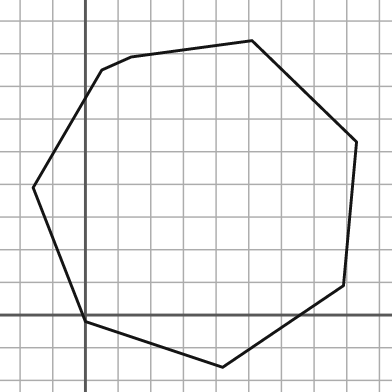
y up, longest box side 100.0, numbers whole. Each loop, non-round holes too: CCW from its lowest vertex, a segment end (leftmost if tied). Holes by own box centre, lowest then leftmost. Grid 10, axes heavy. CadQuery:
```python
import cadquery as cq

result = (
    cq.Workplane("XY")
    .moveTo(42.0, -16.0)
    .lineTo(79.0, 9.0)
    .lineTo(83.0, 53.0)
    .lineTo(51.0, 84.0)
    .lineTo(14.0, 79.0)
    .lineTo(5.0, 75.0)
    .lineTo(-16.0, 39.0)
    .lineTo(0.0, -2.0)
    .close()
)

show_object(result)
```